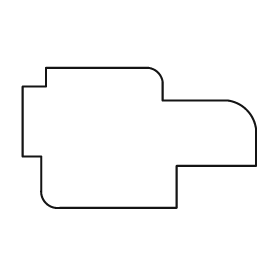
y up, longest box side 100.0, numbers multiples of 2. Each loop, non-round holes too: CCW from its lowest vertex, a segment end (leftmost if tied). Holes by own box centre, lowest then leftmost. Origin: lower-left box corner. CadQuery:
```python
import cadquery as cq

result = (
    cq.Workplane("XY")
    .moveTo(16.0, 0.0)
    .lineTo(66.0, 0.0)
    .lineTo(66.0, 18.0)
    .lineTo(100.0, 18.0)
    .lineTo(100.0, 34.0)
    .threePointArc((96.0, 42.0), (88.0, 46.0))
    .lineTo(60.0, 46.0)
    .lineTo(60.0, 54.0)
    .threePointArc((58.0, 58.0), (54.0, 60.0))
    .lineTo(10.0, 60.0)
    .lineTo(10.0, 52.0)
    .lineTo(0.0, 52.0)
    .lineTo(0.0, 22.0)
    .lineTo(8.0, 22.0)
    .lineTo(8.0, 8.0)
    .threePointArc((10.0, 2.0), (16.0, 0.0))
    .close()
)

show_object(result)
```